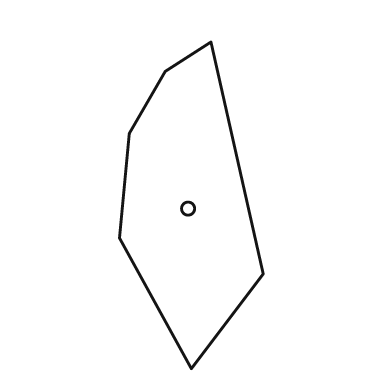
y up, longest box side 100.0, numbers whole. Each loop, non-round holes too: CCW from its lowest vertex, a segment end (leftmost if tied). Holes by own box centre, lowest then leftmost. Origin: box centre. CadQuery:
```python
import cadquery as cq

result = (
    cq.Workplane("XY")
    .moveTo(0.0, -50.0)
    .lineTo(22.0, -21.0)
    .lineTo(6.0, 50.0)
    .lineTo(-8.0, 41.0)
    .lineTo(-19.0, 22.0)
    .lineTo(-22.0, -10.0)
    .close()
    .moveTo(-1.0, -1.0)
    .circle(2.0)
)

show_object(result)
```